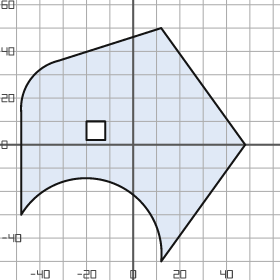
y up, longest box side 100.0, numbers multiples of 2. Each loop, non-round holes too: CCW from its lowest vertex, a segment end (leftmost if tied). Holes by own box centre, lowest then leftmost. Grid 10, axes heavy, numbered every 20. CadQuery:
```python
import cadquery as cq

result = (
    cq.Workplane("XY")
    .moveTo(12.0, -50.0)
    .lineTo(48.0, 0.0)
    .lineTo(12.0, 50.0)
    .lineTo(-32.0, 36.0)
    .threePointArc((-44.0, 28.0), (-48.0, 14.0))
    .lineTo(-48.0, -30.0)
    .threePointArc((-10.0, -16.0), (12.0, -50.0))
    .close()
    .moveTo(-20.0, 2.0)
    .lineTo(-12.0, 2.0)
    .lineTo(-12.0, 10.0)
    .lineTo(-20.0, 10.0)
    .close()
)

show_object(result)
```